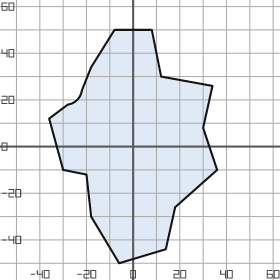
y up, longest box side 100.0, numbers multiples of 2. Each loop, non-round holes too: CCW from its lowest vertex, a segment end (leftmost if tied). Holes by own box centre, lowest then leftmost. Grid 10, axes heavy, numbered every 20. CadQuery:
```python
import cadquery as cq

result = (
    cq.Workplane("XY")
    .moveTo(-6.0, -50.0)
    .lineTo(14.0, -44.0)
    .lineTo(18.0, -26.0)
    .lineTo(36.0, -10.0)
    .lineTo(30.0, 8.0)
    .lineTo(34.0, 26.0)
    .lineTo(12.0, 30.0)
    .lineTo(8.0, 50.0)
    .lineTo(-8.0, 50.0)
    .lineTo(-18.0, 34.0)
    .lineTo(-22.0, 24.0)
    .threePointArc((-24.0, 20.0), (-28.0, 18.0))
    .lineTo(-36.0, 12.0)
    .lineTo(-30.0, -10.0)
    .lineTo(-20.0, -12.0)
    .lineTo(-18.0, -30.0)
    .close()
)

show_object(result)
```